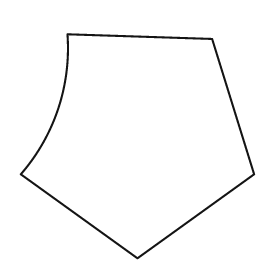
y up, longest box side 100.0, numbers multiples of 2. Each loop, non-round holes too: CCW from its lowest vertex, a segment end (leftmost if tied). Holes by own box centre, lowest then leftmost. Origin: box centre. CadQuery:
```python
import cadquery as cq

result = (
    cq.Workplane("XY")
    .moveTo(0.0, -48.0)
    .lineTo(50.0, -12.0)
    .lineTo(32.0, 46.0)
    .lineTo(-30.0, 48.0)
    .threePointArc((-34.0, 16.0), (-50.0, -12.0))
    .close()
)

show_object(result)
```